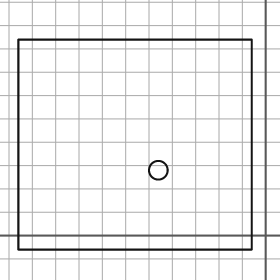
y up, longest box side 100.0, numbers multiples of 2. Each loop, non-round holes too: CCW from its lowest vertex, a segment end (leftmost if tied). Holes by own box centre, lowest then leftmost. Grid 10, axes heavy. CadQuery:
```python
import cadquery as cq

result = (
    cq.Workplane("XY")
    .moveTo(-106.0, -6.0)
    .lineTo(-6.0, -6.0)
    .lineTo(-6.0, 84.0)
    .lineTo(-106.0, 84.0)
    .close()
    .moveTo(-46.0, 28.0)
    .circle(4.0)
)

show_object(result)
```